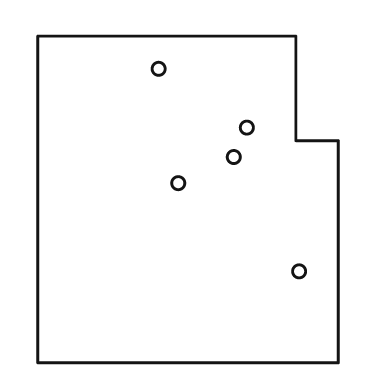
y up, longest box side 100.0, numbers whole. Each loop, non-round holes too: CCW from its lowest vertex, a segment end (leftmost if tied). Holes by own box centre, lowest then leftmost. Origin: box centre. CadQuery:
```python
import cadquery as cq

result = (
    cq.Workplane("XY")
    .moveTo(-46.0, -50.0)
    .lineTo(46.0, -50.0)
    .lineTo(46.0, 18.0)
    .lineTo(33.0, 18.0)
    .lineTo(33.0, 50.0)
    .lineTo(-46.0, 50.0)
    .close()
    .moveTo(34.0, -22.0)
    .circle(2.0)
    .moveTo(-3.0, 5.0)
    .circle(2.0)
    .moveTo(14.0, 13.0)
    .circle(2.0)
    .moveTo(18.0, 22.0)
    .circle(2.0)
    .moveTo(-9.0, 40.0)
    .circle(2.0)
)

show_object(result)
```